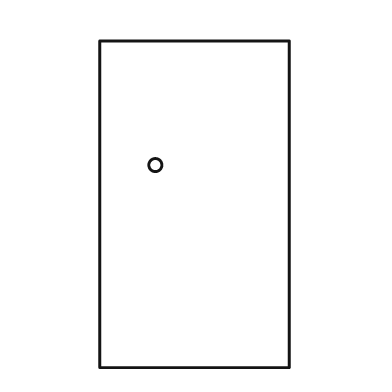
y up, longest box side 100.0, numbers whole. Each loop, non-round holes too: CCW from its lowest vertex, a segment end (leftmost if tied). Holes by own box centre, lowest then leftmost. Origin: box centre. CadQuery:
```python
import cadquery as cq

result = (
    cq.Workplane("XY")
    .moveTo(-29.0, -50.0)
    .lineTo(29.0, -50.0)
    .lineTo(29.0, 50.0)
    .lineTo(-29.0, 50.0)
    .close()
    .moveTo(-12.0, 12.0)
    .circle(2.0)
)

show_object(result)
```